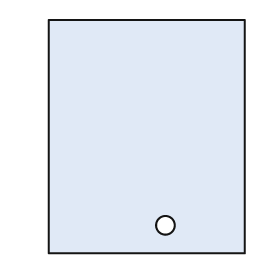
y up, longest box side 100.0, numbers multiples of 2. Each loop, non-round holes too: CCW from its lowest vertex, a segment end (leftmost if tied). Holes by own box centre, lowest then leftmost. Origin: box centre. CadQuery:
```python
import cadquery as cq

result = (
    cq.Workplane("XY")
    .moveTo(-42.0, -50.0)
    .lineTo(42.0, -50.0)
    .lineTo(42.0, 50.0)
    .lineTo(-42.0, 50.0)
    .close()
    .moveTo(8.0, -38.0)
    .circle(4.0)
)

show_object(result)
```